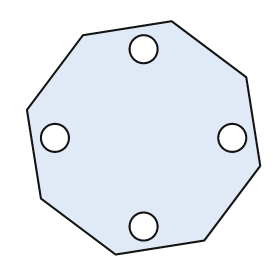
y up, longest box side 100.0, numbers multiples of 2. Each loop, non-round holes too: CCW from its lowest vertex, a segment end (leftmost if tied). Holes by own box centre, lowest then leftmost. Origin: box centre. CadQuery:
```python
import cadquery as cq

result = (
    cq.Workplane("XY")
    .moveTo(-12.0, -50.0)
    .lineTo(26.0, -44.0)
    .lineTo(50.0, -12.0)
    .lineTo(44.0, 26.0)
    .lineTo(12.0, 50.0)
    .lineTo(-26.0, 44.0)
    .lineTo(-50.0, 12.0)
    .lineTo(-44.0, -26.0)
    .close()
    .moveTo(0.0, -38.0)
    .circle(6.0)
    .moveTo(-38.0, 0.0)
    .circle(6.0)
    .moveTo(38.0, 0.0)
    .circle(6.0)
    .moveTo(0.0, 38.0)
    .circle(6.0)
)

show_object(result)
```